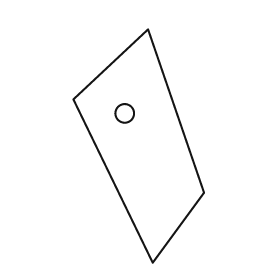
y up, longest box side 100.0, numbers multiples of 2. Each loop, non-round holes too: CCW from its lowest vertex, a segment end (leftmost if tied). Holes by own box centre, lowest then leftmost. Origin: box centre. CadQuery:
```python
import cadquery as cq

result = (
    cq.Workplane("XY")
    .moveTo(6.0, -50.0)
    .lineTo(28.0, -20.0)
    .lineTo(4.0, 50.0)
    .lineTo(-28.0, 20.0)
    .close()
    .moveTo(-6.0, 14.0)
    .circle(4.0)
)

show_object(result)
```